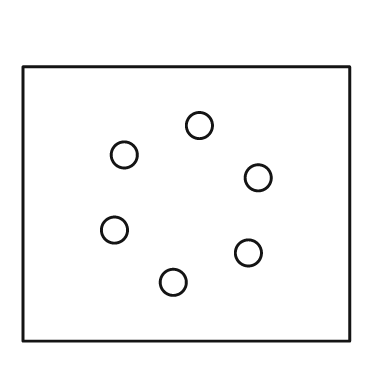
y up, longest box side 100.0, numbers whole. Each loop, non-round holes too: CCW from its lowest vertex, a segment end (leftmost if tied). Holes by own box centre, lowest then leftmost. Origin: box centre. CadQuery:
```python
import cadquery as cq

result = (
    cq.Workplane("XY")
    .moveTo(-50.0, -42.0)
    .lineTo(50.0, -42.0)
    .lineTo(50.0, 42.0)
    .lineTo(-50.0, 42.0)
    .close()
    .moveTo(-4.0, -24.0)
    .circle(4.0)
    .moveTo(19.0, -15.0)
    .circle(4.0)
    .moveTo(-22.0, -8.0)
    .circle(4.0)
    .moveTo(22.0, 8.0)
    .circle(4.0)
    .moveTo(-19.0, 15.0)
    .circle(4.0)
    .moveTo(4.0, 24.0)
    .circle(4.0)
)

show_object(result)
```